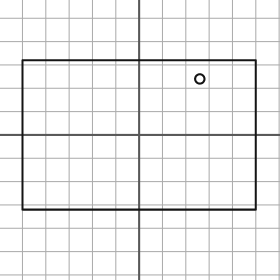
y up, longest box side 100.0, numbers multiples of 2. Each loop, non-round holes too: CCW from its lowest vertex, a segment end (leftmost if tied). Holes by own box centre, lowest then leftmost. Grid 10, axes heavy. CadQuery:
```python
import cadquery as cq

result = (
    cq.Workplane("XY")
    .moveTo(-50.0, -32.0)
    .lineTo(50.0, -32.0)
    .lineTo(50.0, 32.0)
    .lineTo(-50.0, 32.0)
    .close()
    .moveTo(26.0, 24.0)
    .circle(2.0)
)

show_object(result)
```